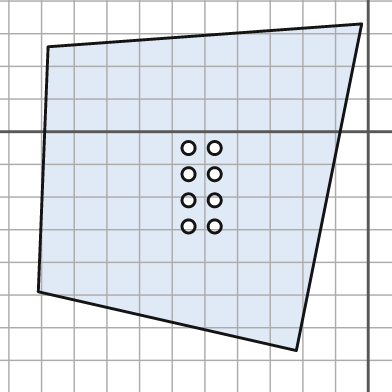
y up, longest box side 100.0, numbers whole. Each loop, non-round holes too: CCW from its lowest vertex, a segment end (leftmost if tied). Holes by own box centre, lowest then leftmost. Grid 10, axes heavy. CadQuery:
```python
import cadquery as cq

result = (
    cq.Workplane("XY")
    .moveTo(-22.0, -67.0)
    .lineTo(-2.0, 33.0)
    .lineTo(-98.0, 26.0)
    .lineTo(-101.0, -49.0)
    .close()
    .moveTo(-55.0, -29.0)
    .circle(2.0)
    .moveTo(-47.0, -29.0)
    .circle(2.0)
    .moveTo(-55.0, -21.0)
    .circle(2.0)
    .moveTo(-47.0, -21.0)
    .circle(2.0)
    .moveTo(-55.0, -13.0)
    .circle(2.0)
    .moveTo(-47.0, -13.0)
    .circle(2.0)
    .moveTo(-55.0, -5.0)
    .circle(2.0)
    .moveTo(-47.0, -5.0)
    .circle(2.0)
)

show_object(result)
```